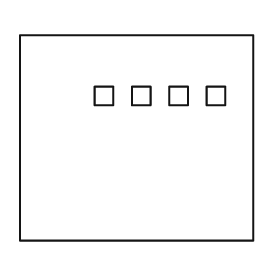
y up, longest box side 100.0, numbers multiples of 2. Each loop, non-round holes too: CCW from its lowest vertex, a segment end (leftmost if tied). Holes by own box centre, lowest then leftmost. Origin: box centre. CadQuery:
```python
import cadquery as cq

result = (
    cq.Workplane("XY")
    .moveTo(-50.0, -44.0)
    .lineTo(50.0, -44.0)
    .lineTo(50.0, 44.0)
    .lineTo(-50.0, 44.0)
    .close()
    .moveTo(-18.0, 14.0)
    .lineTo(-10.0, 14.0)
    .lineTo(-10.0, 22.0)
    .lineTo(-18.0, 22.0)
    .close()
    .moveTo(-2.0, 14.0)
    .lineTo(6.0, 14.0)
    .lineTo(6.0, 22.0)
    .lineTo(-2.0, 22.0)
    .close()
    .moveTo(14.0, 14.0)
    .lineTo(22.0, 14.0)
    .lineTo(22.0, 22.0)
    .lineTo(14.0, 22.0)
    .close()
    .moveTo(30.0, 14.0)
    .lineTo(38.0, 14.0)
    .lineTo(38.0, 22.0)
    .lineTo(30.0, 22.0)
    .close()
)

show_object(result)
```